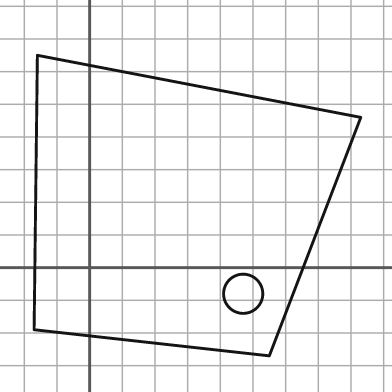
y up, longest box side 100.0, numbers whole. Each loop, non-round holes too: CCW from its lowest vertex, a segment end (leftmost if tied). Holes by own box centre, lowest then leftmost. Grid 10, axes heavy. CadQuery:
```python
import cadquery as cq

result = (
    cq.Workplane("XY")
    .moveTo(55.0, -27.0)
    .lineTo(83.0, 46.0)
    .lineTo(-16.0, 65.0)
    .lineTo(-17.0, -19.0)
    .close()
    .moveTo(47.0, -8.0)
    .circle(6.0)
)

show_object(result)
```